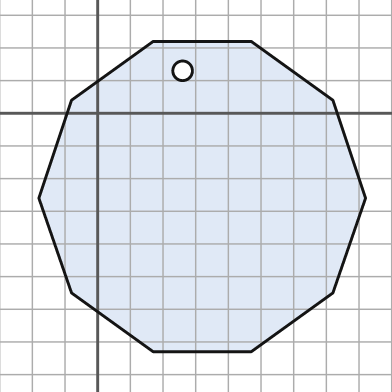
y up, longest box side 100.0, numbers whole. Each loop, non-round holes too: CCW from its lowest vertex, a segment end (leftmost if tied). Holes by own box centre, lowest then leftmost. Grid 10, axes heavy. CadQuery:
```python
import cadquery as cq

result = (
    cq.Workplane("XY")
    .moveTo(17.0, -73.0)
    .lineTo(47.0, -73.0)
    .lineTo(72.0, -55.0)
    .lineTo(82.0, -26.0)
    .lineTo(72.0, 4.0)
    .lineTo(47.0, 22.0)
    .lineTo(17.0, 22.0)
    .lineTo(-8.0, 4.0)
    .lineTo(-18.0, -26.0)
    .lineTo(-8.0, -55.0)
    .close()
    .moveTo(26.0, 13.0)
    .circle(3.0)
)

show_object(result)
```